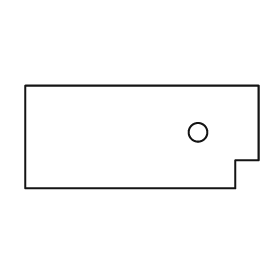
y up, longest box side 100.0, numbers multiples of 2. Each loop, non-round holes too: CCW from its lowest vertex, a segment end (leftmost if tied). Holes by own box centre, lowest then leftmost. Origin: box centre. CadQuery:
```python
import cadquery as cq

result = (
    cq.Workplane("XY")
    .moveTo(-50.0, -22.0)
    .lineTo(40.0, -22.0)
    .lineTo(40.0, -10.0)
    .lineTo(50.0, -10.0)
    .lineTo(50.0, 22.0)
    .lineTo(-50.0, 22.0)
    .close()
    .moveTo(24.0, 2.0)
    .circle(4.0)
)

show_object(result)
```